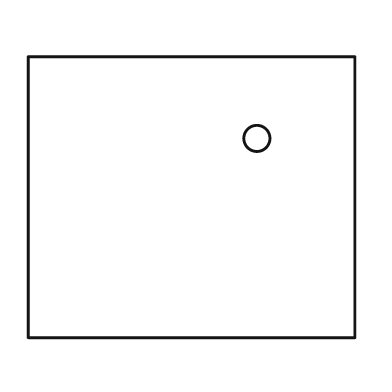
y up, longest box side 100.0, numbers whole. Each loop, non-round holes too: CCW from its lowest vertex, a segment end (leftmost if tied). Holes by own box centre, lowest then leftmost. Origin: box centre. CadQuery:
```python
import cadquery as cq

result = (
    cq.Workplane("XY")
    .moveTo(-50.0, -43.0)
    .lineTo(50.0, -43.0)
    .lineTo(50.0, 43.0)
    .lineTo(-50.0, 43.0)
    .close()
    .moveTo(20.0, 18.0)
    .circle(4.0)
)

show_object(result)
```